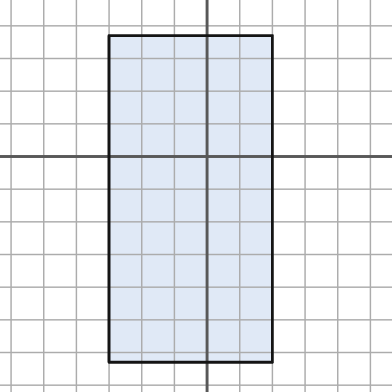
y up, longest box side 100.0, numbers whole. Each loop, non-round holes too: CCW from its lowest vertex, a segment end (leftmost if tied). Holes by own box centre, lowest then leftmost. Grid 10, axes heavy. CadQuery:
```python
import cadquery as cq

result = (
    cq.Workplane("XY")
    .moveTo(-30.0, -63.0)
    .lineTo(20.0, -63.0)
    .lineTo(20.0, 37.0)
    .lineTo(-30.0, 37.0)
    .close()
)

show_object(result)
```